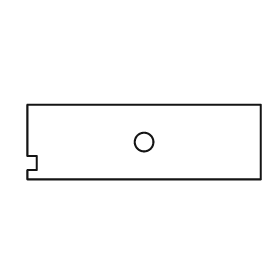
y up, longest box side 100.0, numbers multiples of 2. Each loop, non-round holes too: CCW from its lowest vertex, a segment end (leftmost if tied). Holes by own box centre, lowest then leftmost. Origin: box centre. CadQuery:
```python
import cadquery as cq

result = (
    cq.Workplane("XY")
    .moveTo(-50.0, -16.0)
    .lineTo(50.0, -16.0)
    .lineTo(50.0, 16.0)
    .lineTo(-50.0, 16.0)
    .lineTo(-50.0, -6.0)
    .lineTo(-46.0, -6.0)
    .lineTo(-46.0, -12.0)
    .lineTo(-50.0, -12.0)
    .close()
    .moveTo(0.0, 0.0)
    .circle(4.0)
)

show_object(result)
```